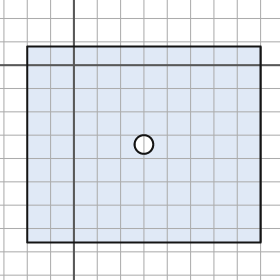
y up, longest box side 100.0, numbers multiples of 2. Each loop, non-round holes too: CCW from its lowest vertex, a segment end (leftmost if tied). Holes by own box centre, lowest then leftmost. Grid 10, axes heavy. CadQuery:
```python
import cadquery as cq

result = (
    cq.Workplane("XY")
    .moveTo(-20.0, -76.0)
    .lineTo(80.0, -76.0)
    .lineTo(80.0, 8.0)
    .lineTo(-20.0, 8.0)
    .close()
    .moveTo(30.0, -34.0)
    .circle(4.0)
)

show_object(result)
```